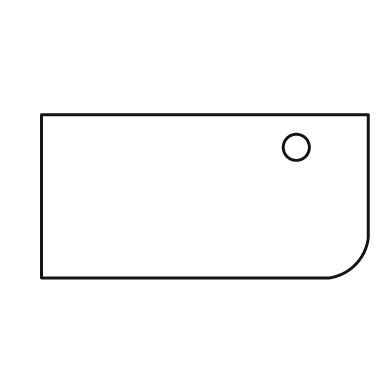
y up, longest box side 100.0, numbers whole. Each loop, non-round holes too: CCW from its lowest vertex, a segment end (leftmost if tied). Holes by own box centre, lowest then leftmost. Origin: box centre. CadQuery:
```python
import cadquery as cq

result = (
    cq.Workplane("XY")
    .moveTo(-50.0, -25.0)
    .lineTo(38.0, -25.0)
    .threePointArc((46.0, -21.0), (50.0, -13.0))
    .lineTo(50.0, 25.0)
    .lineTo(-50.0, 25.0)
    .close()
    .moveTo(28.0, 15.0)
    .circle(4.0)
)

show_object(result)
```